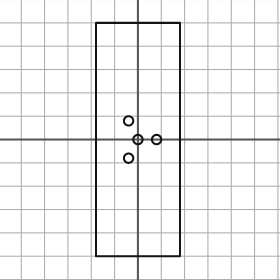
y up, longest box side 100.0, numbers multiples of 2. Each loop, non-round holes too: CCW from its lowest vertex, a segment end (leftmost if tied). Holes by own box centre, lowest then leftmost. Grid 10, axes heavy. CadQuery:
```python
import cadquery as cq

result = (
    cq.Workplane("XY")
    .moveTo(-18.0, -50.0)
    .lineTo(18.0, -50.0)
    .lineTo(18.0, 50.0)
    .lineTo(-18.0, 50.0)
    .close()
    .moveTo(-4.0, -8.0)
    .circle(2.0)
    .moveTo(0.0, 0.0)
    .circle(2.0)
    .moveTo(8.0, 0.0)
    .circle(2.0)
    .moveTo(-4.0, 8.0)
    .circle(2.0)
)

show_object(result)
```